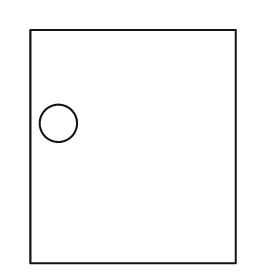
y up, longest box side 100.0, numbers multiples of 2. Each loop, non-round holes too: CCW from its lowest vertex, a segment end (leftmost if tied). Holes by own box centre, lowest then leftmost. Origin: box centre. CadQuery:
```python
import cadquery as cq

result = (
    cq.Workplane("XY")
    .moveTo(-44.0, -50.0)
    .lineTo(44.0, -50.0)
    .lineTo(44.0, 50.0)
    .lineTo(-44.0, 50.0)
    .close()
    .moveTo(-32.0, 10.0)
    .circle(8.0)
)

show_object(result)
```